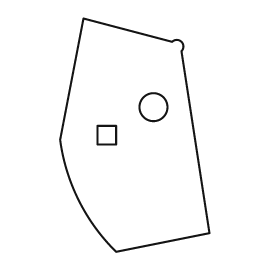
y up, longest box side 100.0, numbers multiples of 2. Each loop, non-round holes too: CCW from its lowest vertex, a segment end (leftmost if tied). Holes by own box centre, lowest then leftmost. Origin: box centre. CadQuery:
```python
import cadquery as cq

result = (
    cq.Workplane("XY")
    .moveTo(-8.0, -50.0)
    .lineTo(32.0, -42.0)
    .lineTo(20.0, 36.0)
    .threePointArc((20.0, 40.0), (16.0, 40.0))
    .lineTo(-22.0, 50.0)
    .lineTo(-32.0, -2.0)
    .threePointArc((-24.0, -28.0), (-8.0, -50.0))
    .close()
    .moveTo(-16.0, -4.0)
    .lineTo(-8.0, -4.0)
    .lineTo(-8.0, 4.0)
    .lineTo(-16.0, 4.0)
    .close()
    .moveTo(8.0, 12.0)
    .circle(6.0)
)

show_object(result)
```